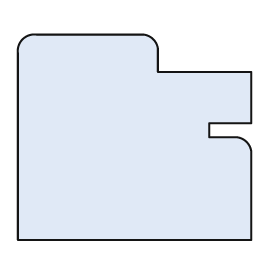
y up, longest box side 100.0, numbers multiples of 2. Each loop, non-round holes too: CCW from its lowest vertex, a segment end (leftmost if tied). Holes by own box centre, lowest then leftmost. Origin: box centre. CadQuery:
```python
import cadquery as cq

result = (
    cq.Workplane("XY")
    .moveTo(-50.0, -44.0)
    .lineTo(50.0, -44.0)
    .lineTo(50.0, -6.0)
    .threePointArc((48.0, -2.0), (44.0, 0.0))
    .lineTo(32.0, 0.0)
    .lineTo(32.0, 6.0)
    .lineTo(50.0, 6.0)
    .lineTo(50.0, 28.0)
    .lineTo(10.0, 28.0)
    .lineTo(10.0, 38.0)
    .threePointArc((8.0, 42.0), (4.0, 44.0))
    .lineTo(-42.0, 44.0)
    .threePointArc((-48.0, 42.0), (-50.0, 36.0))
    .close()
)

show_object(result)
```